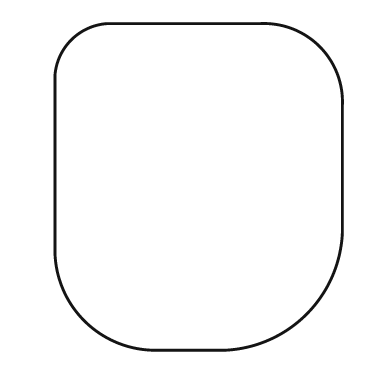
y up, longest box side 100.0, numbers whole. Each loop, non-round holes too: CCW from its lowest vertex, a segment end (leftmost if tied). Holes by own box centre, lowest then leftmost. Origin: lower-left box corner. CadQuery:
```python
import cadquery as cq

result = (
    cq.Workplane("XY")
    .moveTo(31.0, 0.0)
    .lineTo(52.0, 0.0)
    .threePointArc((77.0, 11.0), (88.0, 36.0))
    .lineTo(88.0, 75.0)
    .threePointArc((81.0, 93.0), (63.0, 100.0))
    .lineTo(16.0, 100.0)
    .threePointArc((5.0, 95.0), (0.0, 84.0))
    .lineTo(0.0, 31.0)
    .threePointArc((9.0, 9.0), (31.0, 0.0))
    .close()
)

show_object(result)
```